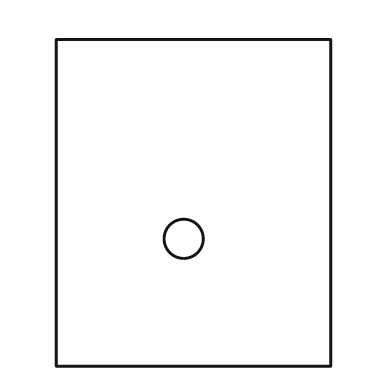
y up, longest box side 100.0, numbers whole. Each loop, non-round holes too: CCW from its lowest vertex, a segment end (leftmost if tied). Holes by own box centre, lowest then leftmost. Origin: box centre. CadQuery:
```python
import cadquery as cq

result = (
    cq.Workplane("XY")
    .moveTo(-42.0, -50.0)
    .lineTo(42.0, -50.0)
    .lineTo(42.0, 50.0)
    .lineTo(-42.0, 50.0)
    .close()
    .moveTo(-3.0, -11.0)
    .circle(6.0)
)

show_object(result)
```